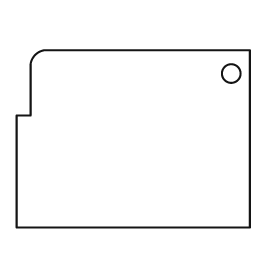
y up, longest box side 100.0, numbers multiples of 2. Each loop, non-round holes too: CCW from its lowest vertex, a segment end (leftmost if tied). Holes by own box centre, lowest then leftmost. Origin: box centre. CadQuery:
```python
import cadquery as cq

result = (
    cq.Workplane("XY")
    .moveTo(-50.0, -38.0)
    .lineTo(50.0, -38.0)
    .lineTo(50.0, 38.0)
    .lineTo(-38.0, 38.0)
    .threePointArc((-42.0, 36.0), (-44.0, 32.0))
    .lineTo(-44.0, 10.0)
    .lineTo(-50.0, 10.0)
    .close()
    .moveTo(42.0, 28.0)
    .circle(4.0)
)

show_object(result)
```